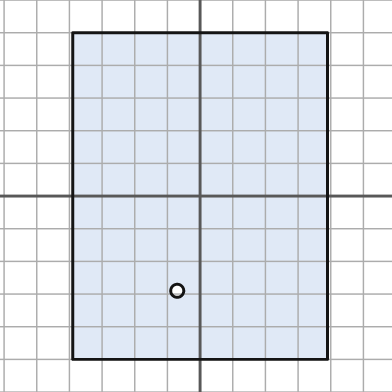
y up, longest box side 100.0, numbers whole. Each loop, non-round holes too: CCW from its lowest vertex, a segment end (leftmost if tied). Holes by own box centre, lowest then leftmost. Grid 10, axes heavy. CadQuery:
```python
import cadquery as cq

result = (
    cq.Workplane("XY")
    .moveTo(-39.0, -50.0)
    .lineTo(39.0, -50.0)
    .lineTo(39.0, 50.0)
    .lineTo(-39.0, 50.0)
    .close()
    .moveTo(-7.0, -29.0)
    .circle(2.0)
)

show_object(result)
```